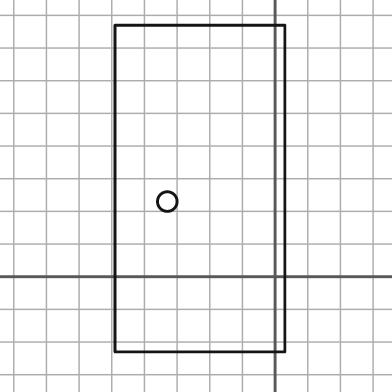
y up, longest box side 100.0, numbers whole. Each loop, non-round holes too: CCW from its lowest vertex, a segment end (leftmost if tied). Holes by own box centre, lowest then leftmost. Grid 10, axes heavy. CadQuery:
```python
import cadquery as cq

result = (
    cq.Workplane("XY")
    .moveTo(-49.0, -23.0)
    .lineTo(3.0, -23.0)
    .lineTo(3.0, 77.0)
    .lineTo(-49.0, 77.0)
    .close()
    .moveTo(-33.0, 23.0)
    .circle(3.0)
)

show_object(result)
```